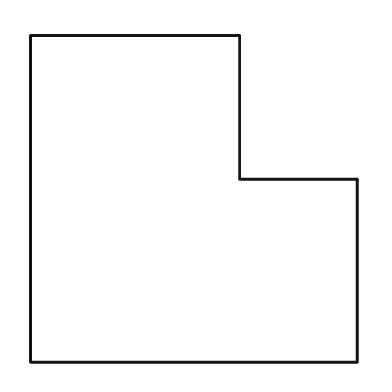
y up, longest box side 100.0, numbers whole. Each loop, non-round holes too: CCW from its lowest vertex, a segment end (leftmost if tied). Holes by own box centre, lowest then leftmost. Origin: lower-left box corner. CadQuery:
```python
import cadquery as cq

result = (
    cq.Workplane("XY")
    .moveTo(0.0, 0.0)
    .lineTo(100.0, 0.0)
    .lineTo(100.0, 56.0)
    .lineTo(64.0, 56.0)
    .lineTo(64.0, 100.0)
    .lineTo(0.0, 100.0)
    .close()
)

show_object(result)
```